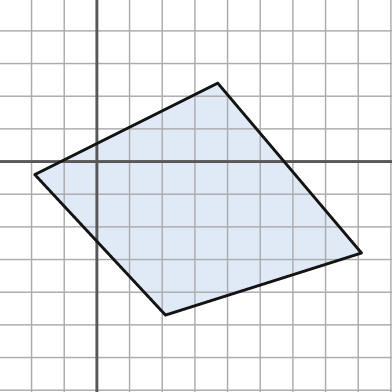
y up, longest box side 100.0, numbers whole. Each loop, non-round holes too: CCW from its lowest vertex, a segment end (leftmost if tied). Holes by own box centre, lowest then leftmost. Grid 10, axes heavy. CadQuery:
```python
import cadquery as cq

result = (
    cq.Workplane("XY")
    .moveTo(21.0, -47.0)
    .lineTo(81.0, -28.0)
    .lineTo(37.0, 24.0)
    .lineTo(-19.0, -4.0)
    .close()
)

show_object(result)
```